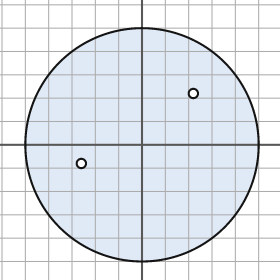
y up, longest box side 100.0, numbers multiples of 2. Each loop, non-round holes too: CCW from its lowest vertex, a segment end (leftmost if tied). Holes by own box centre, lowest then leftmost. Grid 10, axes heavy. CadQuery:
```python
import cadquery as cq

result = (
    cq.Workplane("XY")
    .moveTo(0.0, 0.0)
    .circle(50.0)
    .moveTo(-26.0, -8.0)
    .circle(2.0)
    .moveTo(22.0, 22.0)
    .circle(2.0)
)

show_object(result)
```